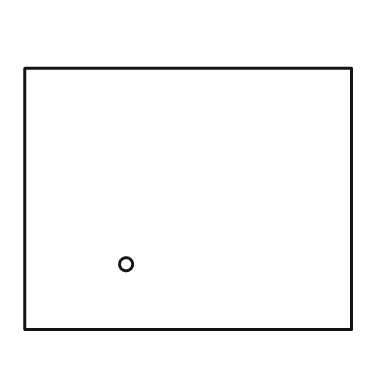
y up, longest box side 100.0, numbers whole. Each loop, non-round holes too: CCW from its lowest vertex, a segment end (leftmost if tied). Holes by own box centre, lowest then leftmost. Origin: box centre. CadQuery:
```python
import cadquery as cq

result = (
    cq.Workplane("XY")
    .moveTo(-50.0, -40.0)
    .lineTo(50.0, -40.0)
    .lineTo(50.0, 40.0)
    .lineTo(-50.0, 40.0)
    .close()
    .moveTo(-19.0, -20.0)
    .circle(2.0)
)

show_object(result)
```